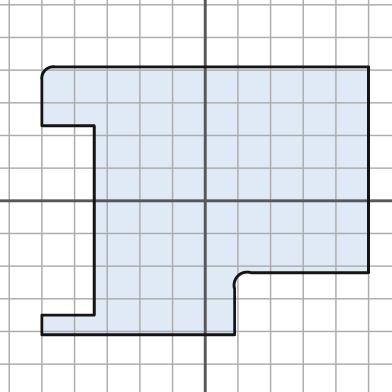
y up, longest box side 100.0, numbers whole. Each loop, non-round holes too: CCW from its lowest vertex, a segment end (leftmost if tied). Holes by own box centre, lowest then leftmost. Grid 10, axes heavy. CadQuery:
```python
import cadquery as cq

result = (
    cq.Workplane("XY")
    .moveTo(-50.0, -41.0)
    .lineTo(9.0, -41.0)
    .lineTo(9.0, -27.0)
    .threePointArc((10.0, -23.0), (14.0, -22.0))
    .lineTo(50.0, -22.0)
    .lineTo(50.0, 41.0)
    .lineTo(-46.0, 41.0)
    .threePointArc((-49.0, 40.0), (-50.0, 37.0))
    .lineTo(-50.0, 23.0)
    .lineTo(-34.0, 23.0)
    .lineTo(-34.0, -35.0)
    .lineTo(-50.0, -35.0)
    .close()
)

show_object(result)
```